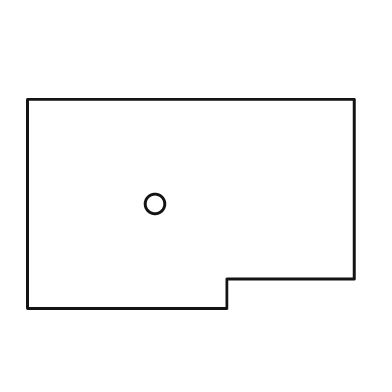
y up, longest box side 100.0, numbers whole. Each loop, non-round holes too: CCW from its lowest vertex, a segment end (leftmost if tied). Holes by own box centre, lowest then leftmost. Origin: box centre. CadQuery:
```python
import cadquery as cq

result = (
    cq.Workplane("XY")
    .moveTo(-50.0, -32.0)
    .lineTo(11.0, -32.0)
    .lineTo(11.0, -23.0)
    .lineTo(50.0, -23.0)
    .lineTo(50.0, 32.0)
    .lineTo(-50.0, 32.0)
    .close()
    .moveTo(-11.0, 0.0)
    .circle(3.0)
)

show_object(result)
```